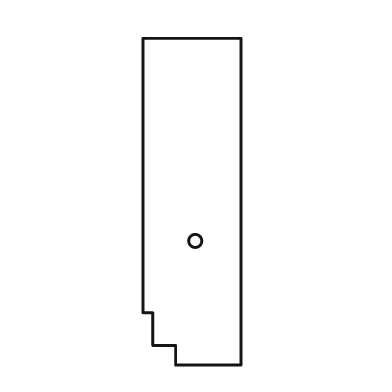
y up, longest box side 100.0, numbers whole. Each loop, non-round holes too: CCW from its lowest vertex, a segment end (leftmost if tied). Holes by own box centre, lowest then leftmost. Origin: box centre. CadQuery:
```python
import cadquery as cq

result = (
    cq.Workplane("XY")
    .moveTo(-5.0, -50.0)
    .lineTo(15.0, -50.0)
    .lineTo(15.0, 50.0)
    .lineTo(-15.0, 50.0)
    .lineTo(-15.0, -34.0)
    .lineTo(-12.0, -34.0)
    .lineTo(-12.0, -44.0)
    .lineTo(-5.0, -44.0)
    .close()
    .moveTo(1.0, -12.0)
    .circle(2.0)
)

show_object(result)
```